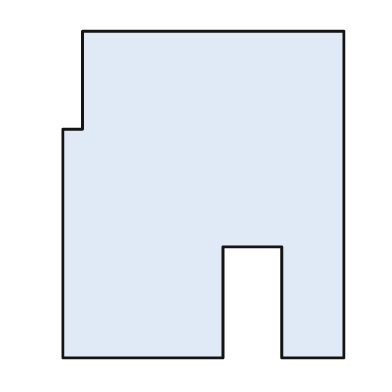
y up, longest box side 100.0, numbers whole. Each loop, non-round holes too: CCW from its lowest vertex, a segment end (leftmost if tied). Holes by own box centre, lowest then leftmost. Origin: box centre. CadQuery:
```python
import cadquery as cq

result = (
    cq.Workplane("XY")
    .moveTo(-43.0, -50.0)
    .lineTo(6.0, -50.0)
    .lineTo(6.0, -16.0)
    .lineTo(24.0, -16.0)
    .lineTo(24.0, -50.0)
    .lineTo(43.0, -50.0)
    .lineTo(43.0, 50.0)
    .lineTo(-37.0, 50.0)
    .lineTo(-37.0, 20.0)
    .lineTo(-43.0, 20.0)
    .close()
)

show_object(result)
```